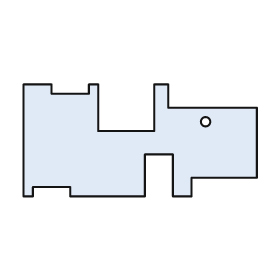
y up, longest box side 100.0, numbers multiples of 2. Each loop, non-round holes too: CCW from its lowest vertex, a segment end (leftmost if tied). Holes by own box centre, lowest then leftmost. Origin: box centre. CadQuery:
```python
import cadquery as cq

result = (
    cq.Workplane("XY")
    .moveTo(-50.0, -24.0)
    .lineTo(-46.0, -24.0)
    .lineTo(-46.0, -20.0)
    .lineTo(-30.0, -20.0)
    .lineTo(-30.0, -24.0)
    .lineTo(2.0, -24.0)
    .lineTo(2.0, -6.0)
    .lineTo(14.0, -6.0)
    .lineTo(14.0, -24.0)
    .lineTo(22.0, -24.0)
    .lineTo(22.0, -16.0)
    .lineTo(50.0, -16.0)
    .lineTo(50.0, 14.0)
    .lineTo(12.0, 14.0)
    .lineTo(12.0, 24.0)
    .lineTo(6.0, 24.0)
    .lineTo(6.0, 4.0)
    .lineTo(-18.0, 4.0)
    .lineTo(-18.0, 24.0)
    .lineTo(-22.0, 24.0)
    .lineTo(-22.0, 20.0)
    .lineTo(-38.0, 20.0)
    .lineTo(-38.0, 24.0)
    .lineTo(-50.0, 24.0)
    .close()
    .moveTo(28.0, 8.0)
    .circle(2.0)
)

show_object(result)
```